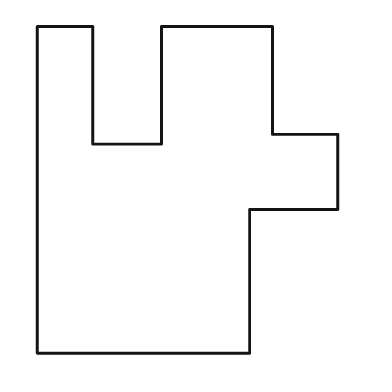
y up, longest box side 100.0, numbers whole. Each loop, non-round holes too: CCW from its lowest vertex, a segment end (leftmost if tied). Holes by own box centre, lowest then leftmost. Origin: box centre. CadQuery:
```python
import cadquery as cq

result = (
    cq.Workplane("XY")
    .moveTo(-46.0, -50.0)
    .lineTo(19.0, -50.0)
    .lineTo(19.0, -6.0)
    .lineTo(46.0, -6.0)
    .lineTo(46.0, 17.0)
    .lineTo(26.0, 17.0)
    .lineTo(26.0, 50.0)
    .lineTo(-8.0, 50.0)
    .lineTo(-8.0, 14.0)
    .lineTo(-29.0, 14.0)
    .lineTo(-29.0, 50.0)
    .lineTo(-46.0, 50.0)
    .close()
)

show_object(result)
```